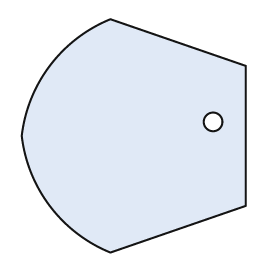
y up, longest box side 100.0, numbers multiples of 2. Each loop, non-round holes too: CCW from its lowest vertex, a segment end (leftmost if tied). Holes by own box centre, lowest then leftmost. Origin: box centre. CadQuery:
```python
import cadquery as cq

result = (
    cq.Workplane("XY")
    .moveTo(-10.0, -50.0)
    .lineTo(48.0, -30.0)
    .lineTo(48.0, 30.0)
    .lineTo(-10.0, 50.0)
    .threePointArc((-36.0, 30.0), (-48.0, 0.0))
    .threePointArc((-36.0, -30.0), (-10.0, -50.0))
    .close()
    .moveTo(34.0, 6.0)
    .circle(4.0)
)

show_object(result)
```